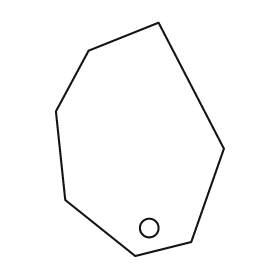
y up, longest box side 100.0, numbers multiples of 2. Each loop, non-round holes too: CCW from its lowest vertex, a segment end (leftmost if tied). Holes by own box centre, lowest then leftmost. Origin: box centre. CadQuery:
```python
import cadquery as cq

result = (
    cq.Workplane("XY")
    .moveTo(-2.0, -50.0)
    .lineTo(22.0, -44.0)
    .lineTo(36.0, -4.0)
    .lineTo(8.0, 50.0)
    .lineTo(-22.0, 38.0)
    .lineTo(-36.0, 12.0)
    .lineTo(-32.0, -26.0)
    .close()
    .moveTo(4.0, -38.0)
    .circle(4.0)
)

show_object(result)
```